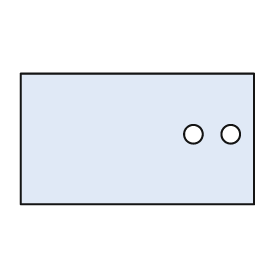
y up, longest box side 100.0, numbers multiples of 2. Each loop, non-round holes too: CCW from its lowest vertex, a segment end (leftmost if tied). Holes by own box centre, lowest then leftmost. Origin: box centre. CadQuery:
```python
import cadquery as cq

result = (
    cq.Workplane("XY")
    .moveTo(-50.0, -28.0)
    .lineTo(50.0, -28.0)
    .lineTo(50.0, 28.0)
    .lineTo(-50.0, 28.0)
    .close()
    .moveTo(24.0, 2.0)
    .circle(4.0)
    .moveTo(40.0, 2.0)
    .circle(4.0)
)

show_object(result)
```